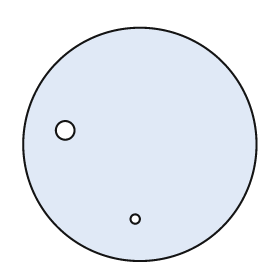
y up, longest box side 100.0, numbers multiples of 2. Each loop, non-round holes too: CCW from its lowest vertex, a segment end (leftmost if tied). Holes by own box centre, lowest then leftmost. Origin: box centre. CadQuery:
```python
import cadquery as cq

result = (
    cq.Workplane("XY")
    .moveTo(0.0, 0.0)
    .circle(50.0)
    .moveTo(-2.0, -32.0)
    .circle(2.0)
    .moveTo(-32.0, 6.0)
    .circle(4.0)
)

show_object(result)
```